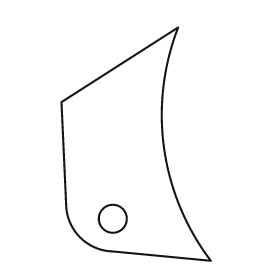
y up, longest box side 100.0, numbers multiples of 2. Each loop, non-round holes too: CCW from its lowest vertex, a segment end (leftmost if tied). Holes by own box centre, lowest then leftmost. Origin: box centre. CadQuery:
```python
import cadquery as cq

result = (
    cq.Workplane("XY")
    .moveTo(32.0, -50.0)
    .threePointArc((12.0, -2.0), (18.0, 50.0))
    .lineTo(-32.0, 18.0)
    .lineTo(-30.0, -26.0)
    .threePointArc((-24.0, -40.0), (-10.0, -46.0))
    .close()
    .moveTo(-10.0, -32.0)
    .circle(6.0)
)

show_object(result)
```